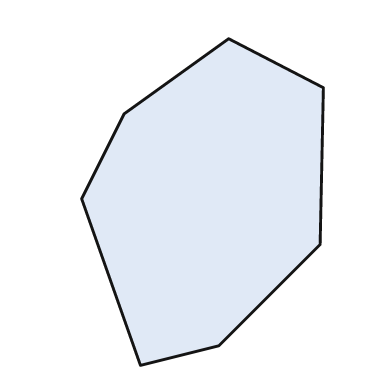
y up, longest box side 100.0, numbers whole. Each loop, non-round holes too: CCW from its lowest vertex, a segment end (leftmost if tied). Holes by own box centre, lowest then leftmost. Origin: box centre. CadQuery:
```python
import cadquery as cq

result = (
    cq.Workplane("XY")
    .moveTo(-19.0, -50.0)
    .lineTo(5.0, -44.0)
    .lineTo(36.0, -13.0)
    .lineTo(37.0, 35.0)
    .lineTo(8.0, 50.0)
    .lineTo(-24.0, 27.0)
    .lineTo(-37.0, 1.0)
    .close()
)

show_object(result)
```